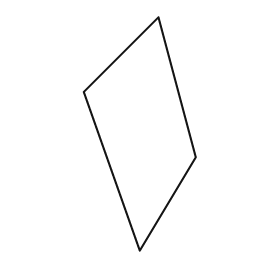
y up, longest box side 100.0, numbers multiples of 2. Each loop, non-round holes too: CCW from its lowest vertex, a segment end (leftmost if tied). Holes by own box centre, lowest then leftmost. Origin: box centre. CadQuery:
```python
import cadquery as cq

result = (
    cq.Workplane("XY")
    .moveTo(0.0, -50.0)
    .lineTo(24.0, -10.0)
    .lineTo(8.0, 50.0)
    .lineTo(-24.0, 18.0)
    .close()
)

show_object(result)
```